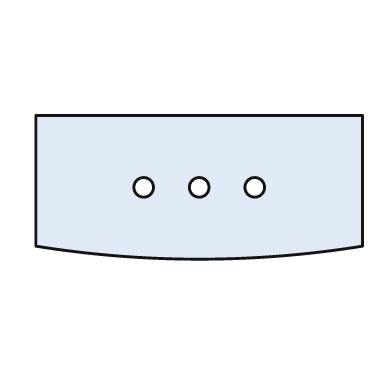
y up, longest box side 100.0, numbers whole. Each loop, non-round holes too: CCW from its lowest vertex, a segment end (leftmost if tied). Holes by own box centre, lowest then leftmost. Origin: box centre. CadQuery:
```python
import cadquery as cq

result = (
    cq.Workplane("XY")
    .moveTo(-50.0, -18.0)
    .threePointArc((0.0, -22.0), (50.0, -18.0))
    .lineTo(50.0, 22.0)
    .lineTo(-50.0, 22.0)
    .close()
    .moveTo(-17.0, 0.0)
    .circle(3.0)
    .moveTo(0.0, 0.0)
    .circle(3.0)
    .moveTo(17.0, 0.0)
    .circle(3.0)
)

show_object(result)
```